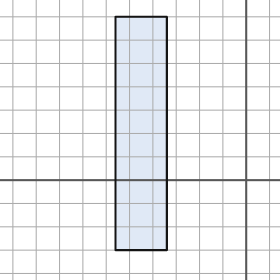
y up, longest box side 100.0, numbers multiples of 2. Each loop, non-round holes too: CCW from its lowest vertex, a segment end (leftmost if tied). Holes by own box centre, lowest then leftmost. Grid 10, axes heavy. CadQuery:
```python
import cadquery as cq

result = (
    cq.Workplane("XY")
    .moveTo(-56.0, -30.0)
    .lineTo(-34.0, -30.0)
    .lineTo(-34.0, 70.0)
    .lineTo(-56.0, 70.0)
    .close()
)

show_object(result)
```